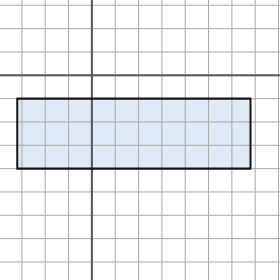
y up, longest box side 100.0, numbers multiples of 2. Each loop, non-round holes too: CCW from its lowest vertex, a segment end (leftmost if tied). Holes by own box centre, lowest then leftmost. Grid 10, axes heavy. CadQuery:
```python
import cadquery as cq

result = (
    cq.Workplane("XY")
    .moveTo(-32.0, -40.0)
    .lineTo(68.0, -40.0)
    .lineTo(68.0, -10.0)
    .lineTo(-32.0, -10.0)
    .close()
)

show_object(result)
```